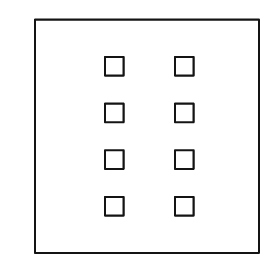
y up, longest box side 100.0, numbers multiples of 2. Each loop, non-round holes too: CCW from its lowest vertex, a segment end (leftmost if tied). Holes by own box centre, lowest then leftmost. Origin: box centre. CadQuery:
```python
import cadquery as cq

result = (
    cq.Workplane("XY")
    .moveTo(-48.0, -50.0)
    .lineTo(48.0, -50.0)
    .lineTo(48.0, 50.0)
    .lineTo(-48.0, 50.0)
    .close()
    .moveTo(-18.0, -34.0)
    .lineTo(-10.0, -34.0)
    .lineTo(-10.0, -26.0)
    .lineTo(-18.0, -26.0)
    .close()
    .moveTo(12.0, -34.0)
    .lineTo(20.0, -34.0)
    .lineTo(20.0, -26.0)
    .lineTo(12.0, -26.0)
    .close()
    .moveTo(-18.0, -14.0)
    .lineTo(-10.0, -14.0)
    .lineTo(-10.0, -6.0)
    .lineTo(-18.0, -6.0)
    .close()
    .moveTo(12.0, -14.0)
    .lineTo(20.0, -14.0)
    .lineTo(20.0, -6.0)
    .lineTo(12.0, -6.0)
    .close()
    .moveTo(-18.0, 6.0)
    .lineTo(-10.0, 6.0)
    .lineTo(-10.0, 14.0)
    .lineTo(-18.0, 14.0)
    .close()
    .moveTo(12.0, 6.0)
    .lineTo(20.0, 6.0)
    .lineTo(20.0, 14.0)
    .lineTo(12.0, 14.0)
    .close()
    .moveTo(-18.0, 26.0)
    .lineTo(-10.0, 26.0)
    .lineTo(-10.0, 34.0)
    .lineTo(-18.0, 34.0)
    .close()
    .moveTo(12.0, 26.0)
    .lineTo(20.0, 26.0)
    .lineTo(20.0, 34.0)
    .lineTo(12.0, 34.0)
    .close()
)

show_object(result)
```